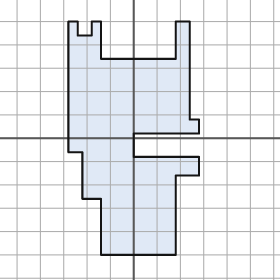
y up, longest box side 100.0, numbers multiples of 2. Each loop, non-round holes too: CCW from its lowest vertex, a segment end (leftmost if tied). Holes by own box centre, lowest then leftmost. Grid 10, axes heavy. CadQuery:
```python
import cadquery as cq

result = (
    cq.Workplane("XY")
    .moveTo(-14.0, -50.0)
    .lineTo(18.0, -50.0)
    .lineTo(18.0, -16.0)
    .lineTo(28.0, -16.0)
    .lineTo(28.0, -8.0)
    .lineTo(0.0, -8.0)
    .lineTo(0.0, 2.0)
    .lineTo(28.0, 2.0)
    .lineTo(28.0, 8.0)
    .lineTo(24.0, 8.0)
    .lineTo(24.0, 50.0)
    .lineTo(18.0, 50.0)
    .lineTo(18.0, 34.0)
    .lineTo(-14.0, 34.0)
    .lineTo(-14.0, 50.0)
    .lineTo(-18.0, 50.0)
    .lineTo(-18.0, 44.0)
    .lineTo(-24.0, 44.0)
    .lineTo(-24.0, 50.0)
    .lineTo(-28.0, 50.0)
    .lineTo(-28.0, -6.0)
    .lineTo(-22.0, -6.0)
    .lineTo(-22.0, -26.0)
    .lineTo(-14.0, -26.0)
    .close()
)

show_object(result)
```